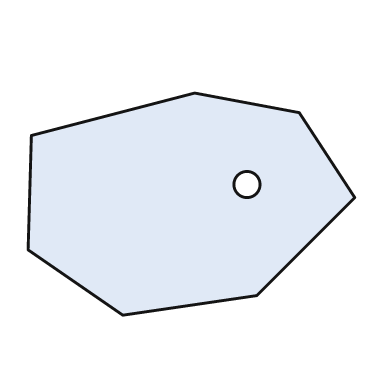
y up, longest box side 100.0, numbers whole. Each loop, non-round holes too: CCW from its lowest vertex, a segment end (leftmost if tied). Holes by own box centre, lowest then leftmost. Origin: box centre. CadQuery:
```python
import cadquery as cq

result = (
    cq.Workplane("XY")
    .moveTo(-21.0, -34.0)
    .lineTo(20.0, -28.0)
    .lineTo(50.0, 2.0)
    .lineTo(33.0, 28.0)
    .lineTo(1.0, 34.0)
    .lineTo(-49.0, 21.0)
    .lineTo(-50.0, -14.0)
    .close()
    .moveTo(17.0, 6.0)
    .circle(4.0)
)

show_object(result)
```